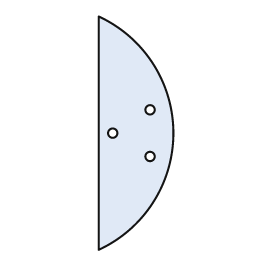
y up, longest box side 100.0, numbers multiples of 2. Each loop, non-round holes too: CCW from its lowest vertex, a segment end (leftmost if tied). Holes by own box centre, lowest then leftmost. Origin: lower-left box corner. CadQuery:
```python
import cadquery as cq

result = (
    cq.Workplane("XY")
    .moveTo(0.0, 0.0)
    .threePointArc((32.0, 50.0), (0.0, 100.0))
    .close()
    .moveTo(22.0, 40.0)
    .circle(2.0)
    .moveTo(6.0, 50.0)
    .circle(2.0)
    .moveTo(22.0, 60.0)
    .circle(2.0)
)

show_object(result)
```